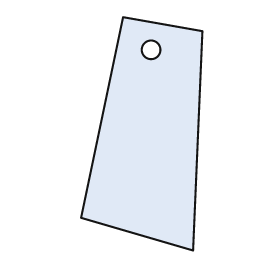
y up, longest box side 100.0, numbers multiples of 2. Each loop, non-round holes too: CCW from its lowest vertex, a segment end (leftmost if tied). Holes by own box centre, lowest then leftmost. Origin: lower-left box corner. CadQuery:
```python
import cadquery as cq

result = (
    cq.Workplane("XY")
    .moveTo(48.0, 0.0)
    .lineTo(52.0, 94.0)
    .lineTo(18.0, 100.0)
    .lineTo(0.0, 14.0)
    .close()
    .moveTo(30.0, 86.0)
    .circle(4.0)
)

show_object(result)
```